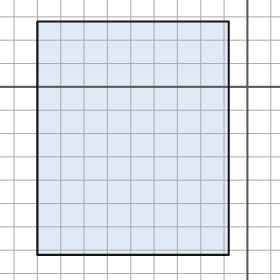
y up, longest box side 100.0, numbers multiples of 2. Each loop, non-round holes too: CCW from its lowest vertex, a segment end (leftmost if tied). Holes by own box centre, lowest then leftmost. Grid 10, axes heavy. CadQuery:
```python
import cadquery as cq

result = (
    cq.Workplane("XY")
    .moveTo(-90.0, -72.0)
    .lineTo(-8.0, -72.0)
    .lineTo(-8.0, 28.0)
    .lineTo(-90.0, 28.0)
    .close()
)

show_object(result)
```